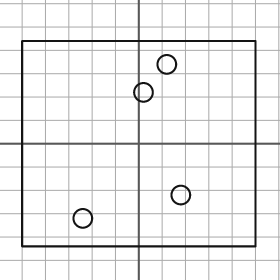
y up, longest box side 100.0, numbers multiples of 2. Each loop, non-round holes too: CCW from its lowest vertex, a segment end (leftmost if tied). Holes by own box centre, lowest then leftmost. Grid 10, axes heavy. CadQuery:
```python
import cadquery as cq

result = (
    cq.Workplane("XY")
    .moveTo(-50.0, -44.0)
    .lineTo(50.0, -44.0)
    .lineTo(50.0, 44.0)
    .lineTo(-50.0, 44.0)
    .close()
    .moveTo(-24.0, -32.0)
    .circle(4.0)
    .moveTo(18.0, -22.0)
    .circle(4.0)
    .moveTo(2.0, 22.0)
    .circle(4.0)
    .moveTo(12.0, 34.0)
    .circle(4.0)
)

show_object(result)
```